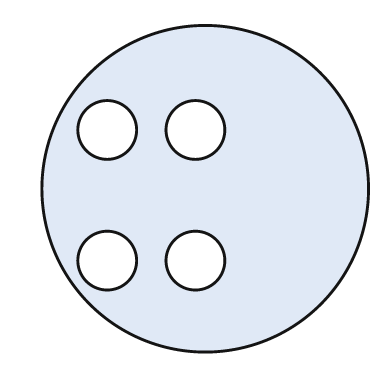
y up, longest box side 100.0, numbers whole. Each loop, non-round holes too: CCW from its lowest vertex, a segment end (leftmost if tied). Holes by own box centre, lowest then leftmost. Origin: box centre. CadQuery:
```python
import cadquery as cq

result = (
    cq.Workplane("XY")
    .moveTo(0.0, 0.0)
    .circle(50.0)
    .moveTo(-30.0, -22.0)
    .circle(9.0)
    .moveTo(-3.0, -22.0)
    .circle(9.0)
    .moveTo(-30.0, 18.0)
    .circle(9.0)
    .moveTo(-3.0, 18.0)
    .circle(9.0)
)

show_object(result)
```